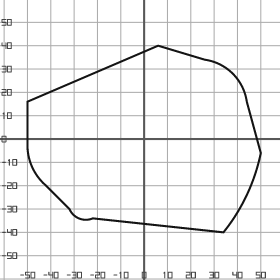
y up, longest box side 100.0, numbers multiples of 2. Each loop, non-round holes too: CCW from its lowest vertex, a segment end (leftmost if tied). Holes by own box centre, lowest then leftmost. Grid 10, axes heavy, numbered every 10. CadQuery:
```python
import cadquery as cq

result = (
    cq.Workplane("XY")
    .moveTo(34.0, -40.0)
    .threePointArc((44.0, -24.0), (50.0, -6.0))
    .lineTo(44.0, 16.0)
    .threePointArc((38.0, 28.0), (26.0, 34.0))
    .lineTo(6.0, 40.0)
    .lineTo(-50.0, 16.0)
    .lineTo(-50.0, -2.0)
    .threePointArc((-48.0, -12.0), (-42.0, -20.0))
    .lineTo(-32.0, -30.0)
    .threePointArc((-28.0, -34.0), (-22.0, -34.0))
    .close()
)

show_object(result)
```